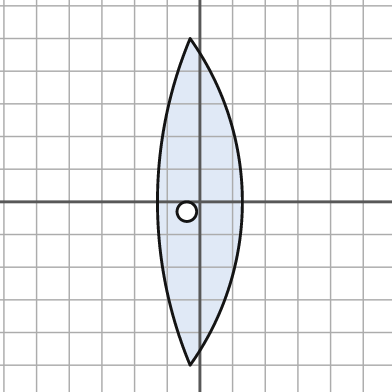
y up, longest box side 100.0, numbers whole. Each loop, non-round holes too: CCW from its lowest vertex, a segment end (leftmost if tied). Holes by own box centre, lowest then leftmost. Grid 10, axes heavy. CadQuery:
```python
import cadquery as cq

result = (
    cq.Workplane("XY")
    .moveTo(-3.0, -50.0)
    .threePointArc((13.0, 0.0), (-3.0, 50.0))
    .threePointArc((-13.0, 0.0), (-3.0, -50.0))
    .close()
    .moveTo(-4.0, -3.0)
    .circle(3.0)
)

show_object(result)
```